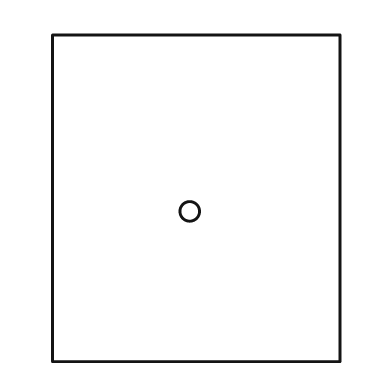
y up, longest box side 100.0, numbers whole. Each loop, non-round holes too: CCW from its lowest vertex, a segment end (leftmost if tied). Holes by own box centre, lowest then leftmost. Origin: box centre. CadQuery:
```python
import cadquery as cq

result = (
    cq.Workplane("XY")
    .moveTo(-44.0, -50.0)
    .lineTo(44.0, -50.0)
    .lineTo(44.0, 50.0)
    .lineTo(-44.0, 50.0)
    .close()
    .moveTo(-2.0, -4.0)
    .circle(3.0)
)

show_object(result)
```